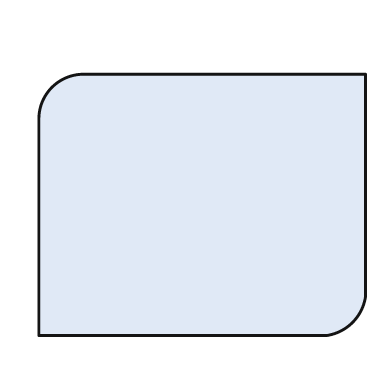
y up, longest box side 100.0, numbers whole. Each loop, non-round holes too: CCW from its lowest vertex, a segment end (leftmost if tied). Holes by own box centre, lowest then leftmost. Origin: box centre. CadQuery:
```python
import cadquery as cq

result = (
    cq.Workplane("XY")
    .moveTo(-50.0, -40.0)
    .lineTo(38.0, -40.0)
    .threePointArc((46.0, -36.0), (50.0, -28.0))
    .lineTo(50.0, 40.0)
    .lineTo(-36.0, 40.0)
    .threePointArc((-46.0, 36.0), (-50.0, 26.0))
    .close()
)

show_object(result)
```